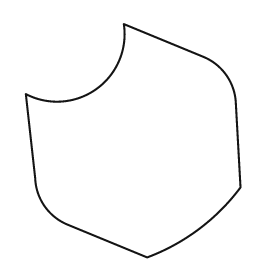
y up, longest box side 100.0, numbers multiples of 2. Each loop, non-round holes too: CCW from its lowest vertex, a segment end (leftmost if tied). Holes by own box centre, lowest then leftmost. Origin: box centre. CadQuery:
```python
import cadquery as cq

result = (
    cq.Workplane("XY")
    .moveTo(6.0, -50.0)
    .threePointArc((28.0, -38.0), (46.0, -20.0))
    .lineTo(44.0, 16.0)
    .threePointArc((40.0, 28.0), (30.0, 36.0))
    .lineTo(-4.0, 50.0)
    .threePointArc((-16.0, 22.0), (-46.0, 20.0))
    .lineTo(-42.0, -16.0)
    .threePointArc((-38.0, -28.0), (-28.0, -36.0))
    .close()
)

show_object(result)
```